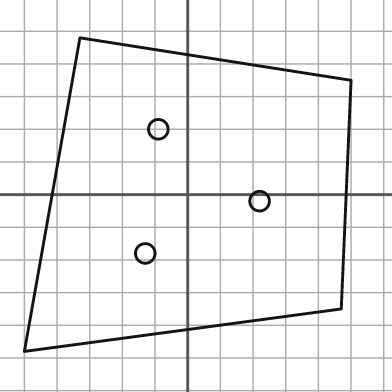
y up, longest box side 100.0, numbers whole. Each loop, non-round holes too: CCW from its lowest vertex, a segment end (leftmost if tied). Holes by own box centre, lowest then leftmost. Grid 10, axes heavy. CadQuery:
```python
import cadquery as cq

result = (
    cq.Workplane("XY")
    .moveTo(-50.0, -48.0)
    .lineTo(47.0, -35.0)
    .lineTo(50.0, 35.0)
    .lineTo(-33.0, 48.0)
    .close()
    .moveTo(-13.0, -18.0)
    .circle(3.0)
    .moveTo(22.0, -2.0)
    .circle(3.0)
    .moveTo(-9.0, 20.0)
    .circle(3.0)
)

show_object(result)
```